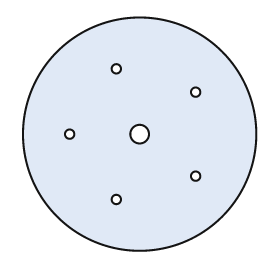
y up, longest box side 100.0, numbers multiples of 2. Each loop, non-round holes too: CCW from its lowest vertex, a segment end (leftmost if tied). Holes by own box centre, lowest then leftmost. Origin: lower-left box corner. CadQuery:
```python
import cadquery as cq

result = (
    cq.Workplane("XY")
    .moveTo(50.0, 50.0)
    .circle(50.0)
    .moveTo(40.0, 22.0)
    .circle(2.0)
    .moveTo(74.0, 32.0)
    .circle(2.0)
    .moveTo(20.0, 50.0)
    .circle(2.0)
    .moveTo(50.0, 50.0)
    .circle(4.0)
    .moveTo(74.0, 68.0)
    .circle(2.0)
    .moveTo(40.0, 78.0)
    .circle(2.0)
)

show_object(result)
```